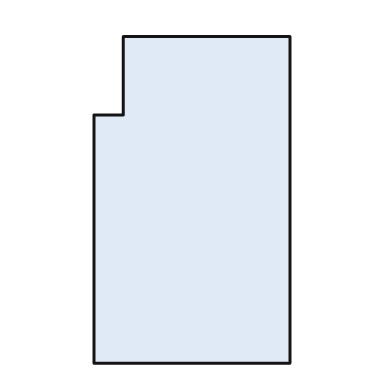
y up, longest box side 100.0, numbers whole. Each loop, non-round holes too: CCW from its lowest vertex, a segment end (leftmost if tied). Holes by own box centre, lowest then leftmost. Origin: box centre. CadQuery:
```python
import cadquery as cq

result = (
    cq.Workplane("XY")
    .moveTo(-30.0, -50.0)
    .lineTo(30.0, -50.0)
    .lineTo(30.0, 50.0)
    .lineTo(-21.0, 50.0)
    .lineTo(-21.0, 26.0)
    .lineTo(-30.0, 26.0)
    .close()
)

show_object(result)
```